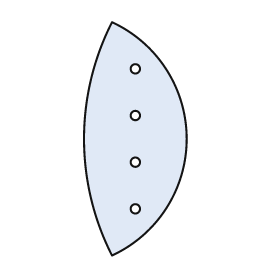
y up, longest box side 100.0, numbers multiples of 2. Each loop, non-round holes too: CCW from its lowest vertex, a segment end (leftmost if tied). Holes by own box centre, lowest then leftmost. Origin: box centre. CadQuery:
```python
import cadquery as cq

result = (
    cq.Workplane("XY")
    .moveTo(-10.0, -50.0)
    .threePointArc((22.0, 0.0), (-10.0, 50.0))
    .threePointArc((-22.0, 0.0), (-10.0, -50.0))
    .close()
    .moveTo(0.0, -30.0)
    .circle(2.0)
    .moveTo(0.0, -10.0)
    .circle(2.0)
    .moveTo(0.0, 10.0)
    .circle(2.0)
    .moveTo(0.0, 30.0)
    .circle(2.0)
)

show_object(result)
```